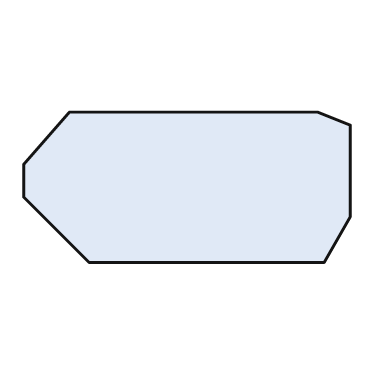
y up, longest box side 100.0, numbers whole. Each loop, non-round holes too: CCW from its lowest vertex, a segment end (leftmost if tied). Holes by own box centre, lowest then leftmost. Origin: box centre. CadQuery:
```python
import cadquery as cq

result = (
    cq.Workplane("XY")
    .moveTo(-30.0, -23.0)
    .lineTo(42.0, -23.0)
    .lineTo(50.0, -9.0)
    .lineTo(50.0, 19.0)
    .lineTo(40.0, 23.0)
    .lineTo(-36.0, 23.0)
    .lineTo(-50.0, 7.0)
    .lineTo(-50.0, -3.0)
    .close()
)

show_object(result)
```